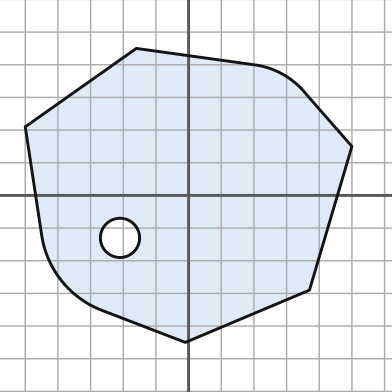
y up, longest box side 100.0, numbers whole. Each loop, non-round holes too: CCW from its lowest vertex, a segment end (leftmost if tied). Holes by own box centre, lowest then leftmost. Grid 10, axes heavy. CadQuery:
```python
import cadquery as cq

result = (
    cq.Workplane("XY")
    .moveTo(-1.0, -45.0)
    .lineTo(37.0, -29.0)
    .lineTo(50.0, 15.0)
    .lineTo(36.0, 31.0)
    .threePointArc((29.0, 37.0), (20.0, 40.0))
    .lineTo(-16.0, 45.0)
    .lineTo(-50.0, 21.0)
    .lineTo(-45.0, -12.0)
    .threePointArc((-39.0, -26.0), (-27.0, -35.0))
    .close()
    .moveTo(-21.0, -13.0)
    .circle(6.0)
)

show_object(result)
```